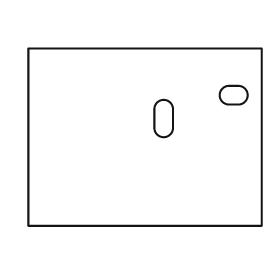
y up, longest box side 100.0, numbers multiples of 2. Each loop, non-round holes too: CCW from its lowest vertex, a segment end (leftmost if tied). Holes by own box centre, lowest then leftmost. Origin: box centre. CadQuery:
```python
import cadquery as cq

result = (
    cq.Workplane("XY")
    .moveTo(-50.0, -38.0)
    .lineTo(50.0, -38.0)
    .lineTo(50.0, 38.0)
    .lineTo(-50.0, 38.0)
    .close()
    .moveTo(4.0, 4.0)
    .threePointArc((8.0, 0.0), (12.0, 4.0))
    .lineTo(12.0, 12.0)
    .threePointArc((8.0, 16.0), (4.0, 12.0))
    .close()
    .moveTo(36.0, 14.0)
    .lineTo(40.0, 14.0)
    .threePointArc((44.0, 18.0), (40.0, 22.0))
    .lineTo(36.0, 22.0)
    .threePointArc((32.0, 18.0), (36.0, 14.0))
    .close()
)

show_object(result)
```